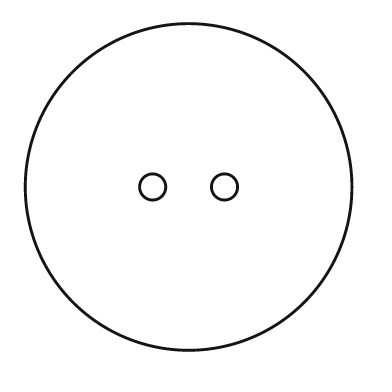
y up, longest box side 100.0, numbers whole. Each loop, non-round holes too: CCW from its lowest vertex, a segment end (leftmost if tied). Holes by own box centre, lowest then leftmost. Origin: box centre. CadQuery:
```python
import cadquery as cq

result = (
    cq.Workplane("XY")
    .moveTo(0.0, 0.0)
    .circle(50.0)
    .moveTo(-11.0, 0.0)
    .circle(4.0)
    .moveTo(11.0, 0.0)
    .circle(4.0)
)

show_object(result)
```